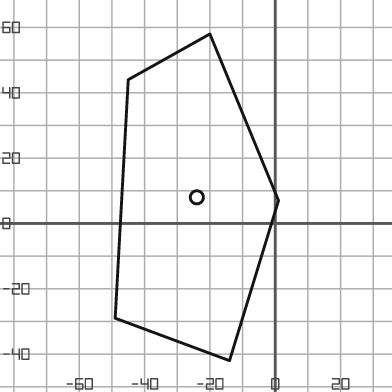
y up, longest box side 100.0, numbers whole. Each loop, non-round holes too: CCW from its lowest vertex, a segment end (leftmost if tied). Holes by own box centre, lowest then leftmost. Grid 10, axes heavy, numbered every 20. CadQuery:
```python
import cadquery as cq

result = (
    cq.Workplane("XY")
    .moveTo(-14.0, -42.0)
    .lineTo(1.0, 7.0)
    .lineTo(-20.0, 58.0)
    .lineTo(-45.0, 44.0)
    .lineTo(-49.0, -29.0)
    .close()
    .moveTo(-24.0, 8.0)
    .circle(2.0)
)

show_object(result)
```